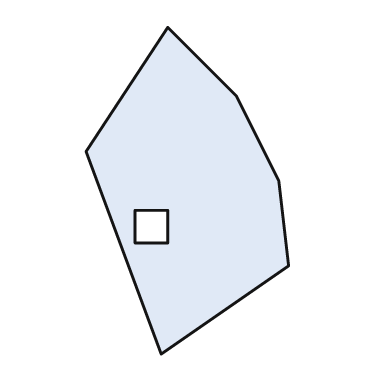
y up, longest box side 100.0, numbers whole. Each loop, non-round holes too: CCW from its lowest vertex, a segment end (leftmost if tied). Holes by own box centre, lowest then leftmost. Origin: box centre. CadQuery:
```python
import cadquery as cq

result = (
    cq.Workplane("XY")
    .moveTo(-8.0, -50.0)
    .lineTo(31.0, -23.0)
    .lineTo(28.0, 3.0)
    .lineTo(15.0, 29.0)
    .lineTo(-6.0, 50.0)
    .lineTo(-31.0, 12.0)
    .close()
    .moveTo(-16.0, -16.0)
    .lineTo(-6.0, -16.0)
    .lineTo(-6.0, -6.0)
    .lineTo(-16.0, -6.0)
    .close()
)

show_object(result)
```